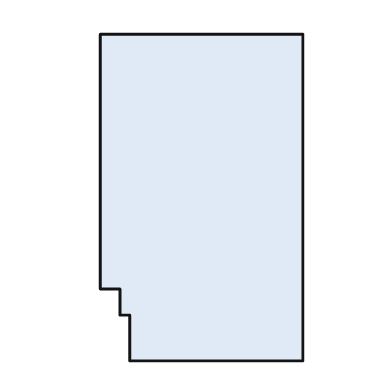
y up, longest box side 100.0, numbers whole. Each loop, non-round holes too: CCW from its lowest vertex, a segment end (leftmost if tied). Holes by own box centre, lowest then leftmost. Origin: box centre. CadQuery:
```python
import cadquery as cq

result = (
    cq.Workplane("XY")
    .moveTo(-22.0, -50.0)
    .lineTo(31.0, -50.0)
    .lineTo(31.0, 50.0)
    .lineTo(-31.0, 50.0)
    .lineTo(-31.0, -28.0)
    .lineTo(-25.0, -28.0)
    .lineTo(-25.0, -36.0)
    .lineTo(-22.0, -36.0)
    .close()
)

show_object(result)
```